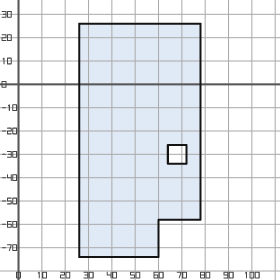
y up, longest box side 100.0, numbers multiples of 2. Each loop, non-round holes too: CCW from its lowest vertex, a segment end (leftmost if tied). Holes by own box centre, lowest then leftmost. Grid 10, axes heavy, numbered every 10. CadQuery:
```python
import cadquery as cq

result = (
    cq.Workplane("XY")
    .moveTo(26.0, -74.0)
    .lineTo(60.0, -74.0)
    .lineTo(60.0, -58.0)
    .lineTo(78.0, -58.0)
    .lineTo(78.0, 26.0)
    .lineTo(26.0, 26.0)
    .close()
    .moveTo(64.0, -34.0)
    .lineTo(72.0, -34.0)
    .lineTo(72.0, -26.0)
    .lineTo(64.0, -26.0)
    .close()
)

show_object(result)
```